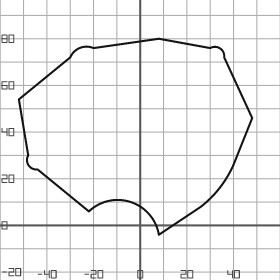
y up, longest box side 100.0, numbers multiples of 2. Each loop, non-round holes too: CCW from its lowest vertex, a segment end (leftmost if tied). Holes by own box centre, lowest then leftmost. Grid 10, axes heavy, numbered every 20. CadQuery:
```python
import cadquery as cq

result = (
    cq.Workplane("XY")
    .moveTo(8.0, -4.0)
    .lineTo(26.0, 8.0)
    .threePointArc((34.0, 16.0), (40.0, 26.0))
    .lineTo(48.0, 46.0)
    .lineTo(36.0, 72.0)
    .threePointArc((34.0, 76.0), (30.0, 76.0))
    .lineTo(8.0, 80.0)
    .lineTo(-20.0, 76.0)
    .threePointArc((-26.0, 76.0), (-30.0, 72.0))
    .lineTo(-52.0, 54.0)
    .lineTo(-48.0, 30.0)
    .threePointArc((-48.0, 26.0), (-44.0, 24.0))
    .lineTo(-22.0, 6.0)
    .threePointArc((-4.0, 10.0), (8.0, -4.0))
    .close()
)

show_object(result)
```